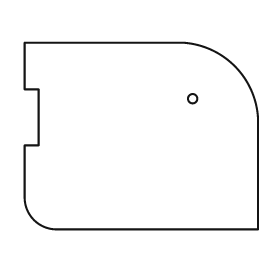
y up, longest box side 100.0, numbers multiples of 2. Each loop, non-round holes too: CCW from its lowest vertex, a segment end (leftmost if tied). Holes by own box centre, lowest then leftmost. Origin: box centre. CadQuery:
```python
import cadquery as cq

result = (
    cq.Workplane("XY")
    .moveTo(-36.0, -40.0)
    .lineTo(50.0, -40.0)
    .lineTo(50.0, 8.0)
    .threePointArc((40.0, 30.0), (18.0, 40.0))
    .lineTo(-50.0, 40.0)
    .lineTo(-50.0, 20.0)
    .lineTo(-44.0, 20.0)
    .lineTo(-44.0, -4.0)
    .lineTo(-50.0, -4.0)
    .lineTo(-50.0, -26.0)
    .threePointArc((-46.0, -36.0), (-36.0, -40.0))
    .close()
    .moveTo(22.0, 16.0)
    .circle(2.0)
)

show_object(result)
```